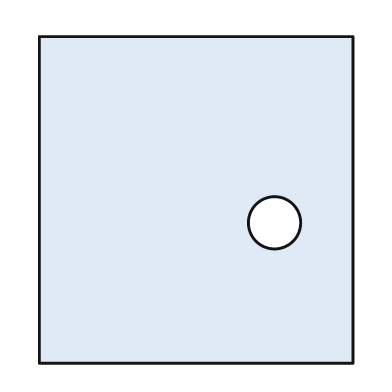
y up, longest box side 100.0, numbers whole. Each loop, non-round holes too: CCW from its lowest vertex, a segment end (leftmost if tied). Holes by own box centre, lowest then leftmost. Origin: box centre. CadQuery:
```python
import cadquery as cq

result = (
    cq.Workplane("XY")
    .moveTo(-48.0, -50.0)
    .lineTo(48.0, -50.0)
    .lineTo(48.0, 50.0)
    .lineTo(-48.0, 50.0)
    .close()
    .moveTo(24.0, -7.0)
    .circle(8.0)
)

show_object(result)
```